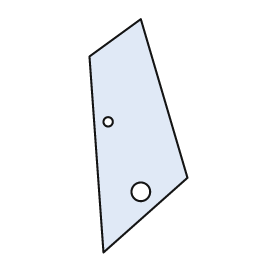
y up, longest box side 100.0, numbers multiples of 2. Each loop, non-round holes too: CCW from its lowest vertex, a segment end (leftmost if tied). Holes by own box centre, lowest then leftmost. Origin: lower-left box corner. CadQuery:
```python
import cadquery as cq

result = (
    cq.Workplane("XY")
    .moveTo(6.0, 0.0)
    .lineTo(42.0, 32.0)
    .lineTo(22.0, 100.0)
    .lineTo(0.0, 84.0)
    .close()
    .moveTo(22.0, 26.0)
    .circle(4.0)
    .moveTo(8.0, 56.0)
    .circle(2.0)
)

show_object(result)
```